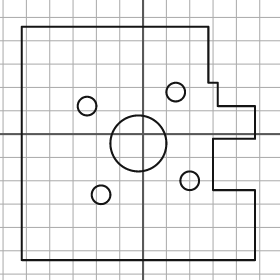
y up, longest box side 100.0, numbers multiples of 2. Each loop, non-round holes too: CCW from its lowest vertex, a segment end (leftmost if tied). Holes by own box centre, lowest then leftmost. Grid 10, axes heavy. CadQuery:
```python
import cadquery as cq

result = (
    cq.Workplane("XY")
    .moveTo(-52.0, -54.0)
    .lineTo(48.0, -54.0)
    .lineTo(48.0, -24.0)
    .lineTo(30.0, -24.0)
    .lineTo(30.0, -2.0)
    .lineTo(48.0, -2.0)
    .lineTo(48.0, 12.0)
    .lineTo(32.0, 12.0)
    .lineTo(32.0, 22.0)
    .lineTo(28.0, 22.0)
    .lineTo(28.0, 46.0)
    .lineTo(-52.0, 46.0)
    .close()
    .moveTo(-18.0, -26.0)
    .circle(4.0)
    .moveTo(20.0, -20.0)
    .circle(4.0)
    .moveTo(-2.0, -4.0)
    .circle(12.0)
    .moveTo(-24.0, 12.0)
    .circle(4.0)
    .moveTo(14.0, 18.0)
    .circle(4.0)
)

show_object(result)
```